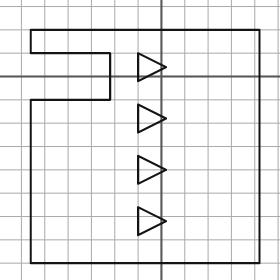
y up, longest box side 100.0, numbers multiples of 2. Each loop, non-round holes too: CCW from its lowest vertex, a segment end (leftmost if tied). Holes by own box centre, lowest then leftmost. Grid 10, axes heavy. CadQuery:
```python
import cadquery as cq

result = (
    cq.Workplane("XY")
    .moveTo(-56.0, -80.0)
    .lineTo(42.0, -80.0)
    .lineTo(42.0, 20.0)
    .lineTo(-56.0, 20.0)
    .lineTo(-56.0, 10.0)
    .lineTo(-22.0, 10.0)
    .lineTo(-22.0, -10.0)
    .lineTo(-56.0, -10.0)
    .close()
    .moveTo(-10.0, -68.0)
    .lineTo(2.0, -62.0)
    .lineTo(-10.0, -56.0)
    .close()
    .moveTo(-10.0, -46.0)
    .lineTo(2.0, -40.0)
    .lineTo(-10.0, -34.0)
    .close()
    .moveTo(-10.0, -24.0)
    .lineTo(2.0, -18.0)
    .lineTo(-10.0, -12.0)
    .close()
    .moveTo(-10.0, -2.0)
    .lineTo(2.0, 4.0)
    .lineTo(-10.0, 10.0)
    .close()
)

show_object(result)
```